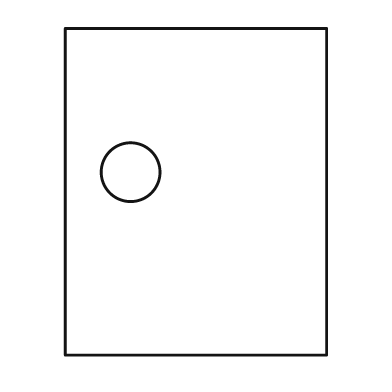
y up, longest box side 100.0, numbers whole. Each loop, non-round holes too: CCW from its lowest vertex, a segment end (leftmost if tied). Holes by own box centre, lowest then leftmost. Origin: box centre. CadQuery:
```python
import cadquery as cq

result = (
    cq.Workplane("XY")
    .moveTo(-40.0, -50.0)
    .lineTo(40.0, -50.0)
    .lineTo(40.0, 50.0)
    .lineTo(-40.0, 50.0)
    .close()
    .moveTo(-20.0, 6.0)
    .circle(9.0)
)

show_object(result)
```